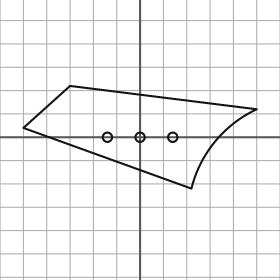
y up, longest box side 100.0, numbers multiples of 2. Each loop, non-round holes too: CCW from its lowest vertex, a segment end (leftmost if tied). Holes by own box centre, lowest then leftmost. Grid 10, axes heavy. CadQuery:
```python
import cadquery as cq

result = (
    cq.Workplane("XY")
    .moveTo(22.0, -22.0)
    .threePointArc((32.0, -2.0), (50.0, 12.0))
    .lineTo(-30.0, 22.0)
    .lineTo(-50.0, 4.0)
    .close()
    .moveTo(-14.0, 0.0)
    .circle(2.0)
    .moveTo(0.0, 0.0)
    .circle(2.0)
    .moveTo(14.0, 0.0)
    .circle(2.0)
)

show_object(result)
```